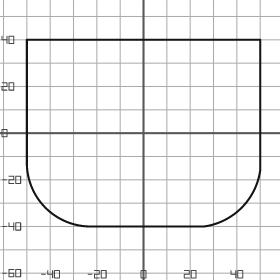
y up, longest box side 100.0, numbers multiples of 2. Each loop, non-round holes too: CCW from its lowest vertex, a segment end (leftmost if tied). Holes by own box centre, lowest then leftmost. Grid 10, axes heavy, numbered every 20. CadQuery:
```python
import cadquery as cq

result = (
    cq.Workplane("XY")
    .moveTo(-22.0, -40.0)
    .lineTo(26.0, -40.0)
    .threePointArc((42.0, -32.0), (50.0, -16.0))
    .lineTo(50.0, 40.0)
    .lineTo(-50.0, 40.0)
    .lineTo(-50.0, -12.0)
    .threePointArc((-42.0, -32.0), (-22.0, -40.0))
    .close()
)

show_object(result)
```